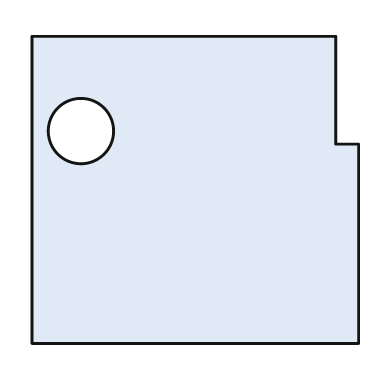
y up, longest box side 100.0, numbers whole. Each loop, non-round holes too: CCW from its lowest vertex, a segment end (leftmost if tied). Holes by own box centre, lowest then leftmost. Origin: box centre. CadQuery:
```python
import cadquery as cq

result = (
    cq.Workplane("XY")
    .moveTo(-50.0, -47.0)
    .lineTo(50.0, -47.0)
    .lineTo(50.0, 14.0)
    .lineTo(43.0, 14.0)
    .lineTo(43.0, 47.0)
    .lineTo(-50.0, 47.0)
    .close()
    .moveTo(-35.0, 18.0)
    .circle(10.0)
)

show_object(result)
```